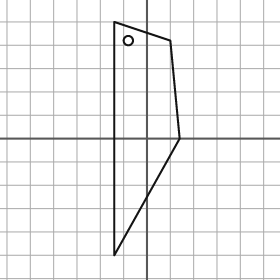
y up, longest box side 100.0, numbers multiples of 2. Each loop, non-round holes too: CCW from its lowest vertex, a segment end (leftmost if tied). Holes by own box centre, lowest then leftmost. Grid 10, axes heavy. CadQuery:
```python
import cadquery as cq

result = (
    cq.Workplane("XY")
    .moveTo(-14.0, -50.0)
    .lineTo(14.0, 0.0)
    .lineTo(10.0, 42.0)
    .lineTo(-14.0, 50.0)
    .close()
    .moveTo(-8.0, 42.0)
    .circle(2.0)
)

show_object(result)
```